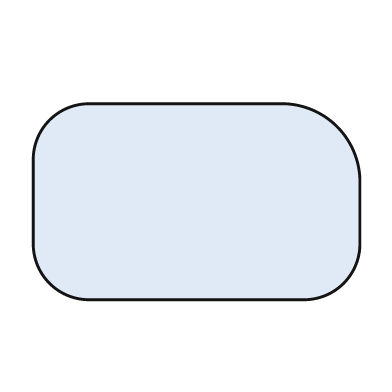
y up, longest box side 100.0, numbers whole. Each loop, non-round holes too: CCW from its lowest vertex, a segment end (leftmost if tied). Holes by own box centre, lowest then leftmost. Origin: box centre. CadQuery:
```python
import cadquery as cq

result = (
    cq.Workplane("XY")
    .moveTo(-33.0, -30.0)
    .lineTo(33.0, -30.0)
    .threePointArc((45.0, -25.0), (50.0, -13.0))
    .lineTo(50.0, 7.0)
    .threePointArc((43.0, 23.0), (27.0, 30.0))
    .lineTo(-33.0, 30.0)
    .threePointArc((-45.0, 25.0), (-50.0, 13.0))
    .lineTo(-50.0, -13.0)
    .threePointArc((-45.0, -25.0), (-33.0, -30.0))
    .close()
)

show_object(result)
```